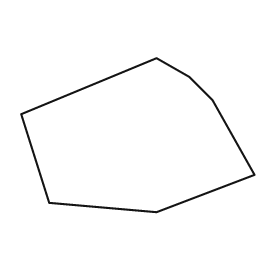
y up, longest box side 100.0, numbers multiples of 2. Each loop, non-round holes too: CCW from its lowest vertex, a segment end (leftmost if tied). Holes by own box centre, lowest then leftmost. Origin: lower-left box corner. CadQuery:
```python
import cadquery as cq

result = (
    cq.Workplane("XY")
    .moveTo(58.0, 0.0)
    .lineTo(100.0, 16.0)
    .lineTo(82.0, 48.0)
    .lineTo(72.0, 58.0)
    .lineTo(58.0, 66.0)
    .lineTo(0.0, 42.0)
    .lineTo(12.0, 4.0)
    .close()
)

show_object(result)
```